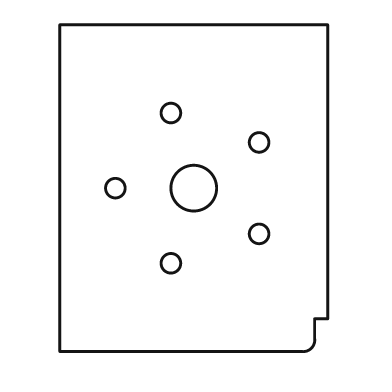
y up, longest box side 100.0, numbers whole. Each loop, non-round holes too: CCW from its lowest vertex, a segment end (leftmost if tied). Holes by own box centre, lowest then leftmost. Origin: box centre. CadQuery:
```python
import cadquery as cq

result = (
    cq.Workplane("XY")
    .moveTo(-41.0, -50.0)
    .lineTo(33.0, -50.0)
    .threePointArc((36.0, -49.0), (37.0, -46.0))
    .lineTo(37.0, -40.0)
    .lineTo(41.0, -40.0)
    .lineTo(41.0, 50.0)
    .lineTo(-41.0, 50.0)
    .close()
    .moveTo(-7.0, -23.0)
    .circle(3.0)
    .moveTo(20.0, -14.0)
    .circle(3.0)
    .moveTo(-24.0, 0.0)
    .circle(3.0)
    .moveTo(0.0, 0.0)
    .circle(7.0)
    .moveTo(20.0, 14.0)
    .circle(3.0)
    .moveTo(-7.0, 23.0)
    .circle(3.0)
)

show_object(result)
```